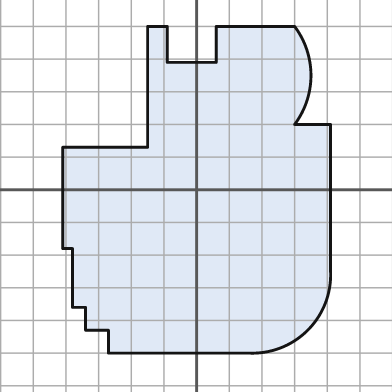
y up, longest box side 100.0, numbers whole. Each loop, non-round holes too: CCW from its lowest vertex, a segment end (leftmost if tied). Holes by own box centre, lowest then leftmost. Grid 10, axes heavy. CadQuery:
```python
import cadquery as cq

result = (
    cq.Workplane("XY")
    .moveTo(-27.0, -50.0)
    .lineTo(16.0, -50.0)
    .threePointArc((34.0, -43.0), (41.0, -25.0))
    .lineTo(41.0, 20.0)
    .lineTo(30.0, 20.0)
    .threePointArc((35.0, 35.0), (30.0, 50.0))
    .lineTo(6.0, 50.0)
    .lineTo(6.0, 39.0)
    .lineTo(-9.0, 39.0)
    .lineTo(-9.0, 50.0)
    .lineTo(-15.0, 50.0)
    .lineTo(-15.0, 13.0)
    .lineTo(-41.0, 13.0)
    .lineTo(-41.0, -18.0)
    .lineTo(-38.0, -18.0)
    .lineTo(-38.0, -36.0)
    .lineTo(-34.0, -36.0)
    .lineTo(-34.0, -43.0)
    .lineTo(-27.0, -43.0)
    .close()
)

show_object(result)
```